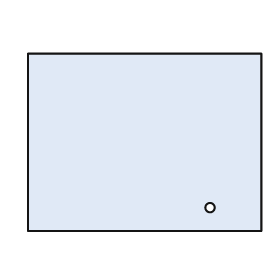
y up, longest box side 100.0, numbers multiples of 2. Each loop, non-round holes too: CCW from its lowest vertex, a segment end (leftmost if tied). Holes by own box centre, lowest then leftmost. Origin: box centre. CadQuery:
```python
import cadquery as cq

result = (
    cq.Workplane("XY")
    .moveTo(-50.0, -38.0)
    .lineTo(50.0, -38.0)
    .lineTo(50.0, 38.0)
    .lineTo(-50.0, 38.0)
    .close()
    .moveTo(28.0, -28.0)
    .circle(2.0)
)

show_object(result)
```